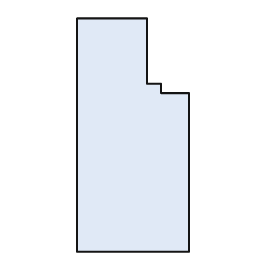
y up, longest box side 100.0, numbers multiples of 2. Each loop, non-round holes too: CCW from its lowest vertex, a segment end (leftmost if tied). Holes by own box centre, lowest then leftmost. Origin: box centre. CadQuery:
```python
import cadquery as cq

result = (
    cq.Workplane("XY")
    .moveTo(-24.0, -50.0)
    .lineTo(24.0, -50.0)
    .lineTo(24.0, 18.0)
    .lineTo(12.0, 18.0)
    .lineTo(12.0, 22.0)
    .lineTo(6.0, 22.0)
    .lineTo(6.0, 50.0)
    .lineTo(-24.0, 50.0)
    .close()
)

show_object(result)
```